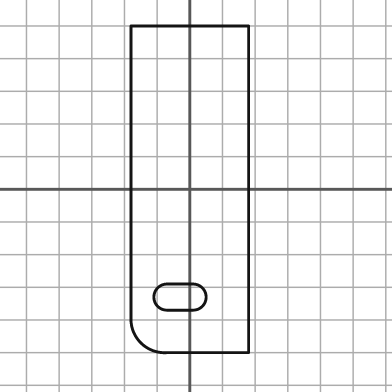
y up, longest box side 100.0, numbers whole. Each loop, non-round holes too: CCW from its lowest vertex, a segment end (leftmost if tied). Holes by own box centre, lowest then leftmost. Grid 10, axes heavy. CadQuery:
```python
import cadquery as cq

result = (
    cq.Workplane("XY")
    .moveTo(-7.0, -50.0)
    .lineTo(18.0, -50.0)
    .lineTo(18.0, 50.0)
    .lineTo(-18.0, 50.0)
    .lineTo(-18.0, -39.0)
    .threePointArc((-15.0, -47.0), (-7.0, -50.0))
    .close()
    .moveTo(-7.0, -37.0)
    .lineTo(1.0, -37.0)
    .threePointArc((5.0, -33.0), (1.0, -29.0))
    .lineTo(-7.0, -29.0)
    .threePointArc((-11.0, -33.0), (-7.0, -37.0))
    .close()
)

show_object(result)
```